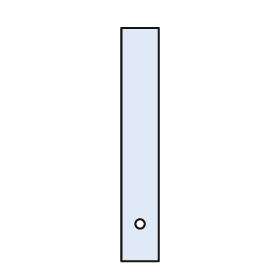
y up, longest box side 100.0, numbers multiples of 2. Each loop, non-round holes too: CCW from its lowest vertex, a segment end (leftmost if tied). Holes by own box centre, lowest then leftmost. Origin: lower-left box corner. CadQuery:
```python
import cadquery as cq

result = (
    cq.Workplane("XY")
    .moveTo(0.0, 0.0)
    .lineTo(16.0, 0.0)
    .lineTo(16.0, 100.0)
    .lineTo(0.0, 100.0)
    .close()
    .moveTo(8.0, 16.0)
    .circle(2.0)
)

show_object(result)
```